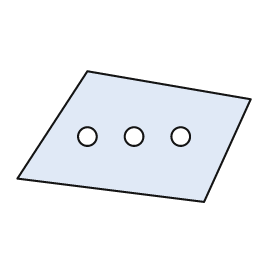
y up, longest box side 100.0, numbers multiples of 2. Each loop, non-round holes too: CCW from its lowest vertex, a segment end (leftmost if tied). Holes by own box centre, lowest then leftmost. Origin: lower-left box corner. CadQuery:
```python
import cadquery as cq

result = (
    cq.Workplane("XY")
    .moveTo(80.0, 0.0)
    .lineTo(100.0, 44.0)
    .lineTo(30.0, 56.0)
    .lineTo(0.0, 10.0)
    .close()
    .moveTo(30.0, 28.0)
    .circle(4.0)
    .moveTo(50.0, 28.0)
    .circle(4.0)
    .moveTo(70.0, 28.0)
    .circle(4.0)
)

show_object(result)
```